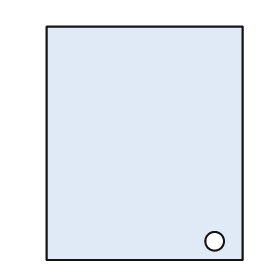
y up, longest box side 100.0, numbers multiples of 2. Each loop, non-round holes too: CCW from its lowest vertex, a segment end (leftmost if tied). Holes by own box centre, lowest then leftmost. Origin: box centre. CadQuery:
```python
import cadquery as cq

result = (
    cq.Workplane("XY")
    .moveTo(-42.0, -50.0)
    .lineTo(42.0, -50.0)
    .lineTo(42.0, 50.0)
    .lineTo(-42.0, 50.0)
    .close()
    .moveTo(30.0, -42.0)
    .circle(4.0)
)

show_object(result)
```